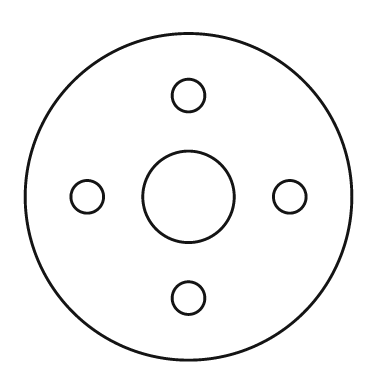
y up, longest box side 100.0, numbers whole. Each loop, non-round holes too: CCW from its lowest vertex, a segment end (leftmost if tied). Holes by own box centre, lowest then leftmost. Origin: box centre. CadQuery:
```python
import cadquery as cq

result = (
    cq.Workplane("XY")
    .moveTo(0.0, 0.0)
    .circle(50.0)
    .moveTo(0.0, -31.0)
    .circle(5.0)
    .moveTo(-31.0, 0.0)
    .circle(5.0)
    .moveTo(0.0, 0.0)
    .circle(14.0)
    .moveTo(31.0, 0.0)
    .circle(5.0)
    .moveTo(0.0, 31.0)
    .circle(5.0)
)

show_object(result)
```